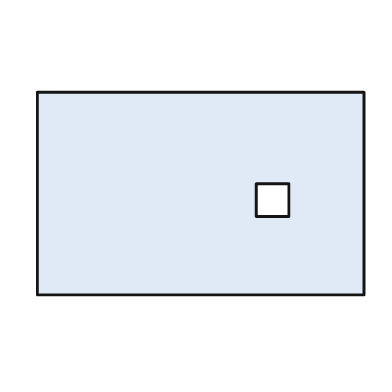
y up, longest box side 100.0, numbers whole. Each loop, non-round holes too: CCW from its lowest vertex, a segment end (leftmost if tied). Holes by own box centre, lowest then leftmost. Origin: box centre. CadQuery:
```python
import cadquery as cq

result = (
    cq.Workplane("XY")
    .moveTo(-50.0, -31.0)
    .lineTo(50.0, -31.0)
    .lineTo(50.0, 31.0)
    .lineTo(-50.0, 31.0)
    .close()
    .moveTo(17.0, -7.0)
    .lineTo(27.0, -7.0)
    .lineTo(27.0, 3.0)
    .lineTo(17.0, 3.0)
    .close()
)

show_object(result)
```